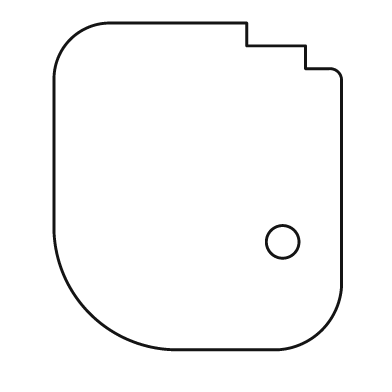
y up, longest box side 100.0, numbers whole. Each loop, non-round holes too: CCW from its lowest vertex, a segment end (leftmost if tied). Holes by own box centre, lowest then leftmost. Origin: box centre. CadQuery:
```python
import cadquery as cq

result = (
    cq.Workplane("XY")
    .moveTo(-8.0, -50.0)
    .lineTo(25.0, -50.0)
    .threePointArc((38.0, -44.0), (44.0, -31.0))
    .lineTo(44.0, 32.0)
    .threePointArc((43.0, 35.0), (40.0, 36.0))
    .lineTo(33.0, 36.0)
    .lineTo(33.0, 43.0)
    .lineTo(15.0, 43.0)
    .lineTo(15.0, 50.0)
    .lineTo(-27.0, 50.0)
    .threePointArc((-39.0, 45.0), (-44.0, 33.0))
    .lineTo(-44.0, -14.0)
    .threePointArc((-33.0, -39.0), (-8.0, -50.0))
    .close()
    .moveTo(26.0, -17.0)
    .circle(5.0)
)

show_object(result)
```